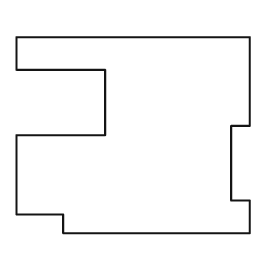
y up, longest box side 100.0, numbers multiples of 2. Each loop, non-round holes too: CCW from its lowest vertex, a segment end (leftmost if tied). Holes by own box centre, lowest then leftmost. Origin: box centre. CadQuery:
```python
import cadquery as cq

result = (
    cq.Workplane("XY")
    .moveTo(-30.0, -42.0)
    .lineTo(50.0, -42.0)
    .lineTo(50.0, -28.0)
    .lineTo(42.0, -28.0)
    .lineTo(42.0, 4.0)
    .lineTo(50.0, 4.0)
    .lineTo(50.0, 42.0)
    .lineTo(-50.0, 42.0)
    .lineTo(-50.0, 28.0)
    .lineTo(-12.0, 28.0)
    .lineTo(-12.0, 0.0)
    .lineTo(-50.0, 0.0)
    .lineTo(-50.0, -34.0)
    .lineTo(-30.0, -34.0)
    .close()
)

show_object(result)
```